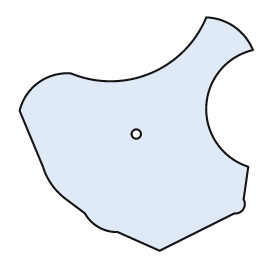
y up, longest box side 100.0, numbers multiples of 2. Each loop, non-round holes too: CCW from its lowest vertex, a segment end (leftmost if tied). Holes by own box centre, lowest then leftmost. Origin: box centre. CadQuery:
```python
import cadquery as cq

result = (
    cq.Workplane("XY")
    .moveTo(10.0, -50.0)
    .lineTo(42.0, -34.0)
    .threePointArc((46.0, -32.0), (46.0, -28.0))
    .lineTo(48.0, -14.0)
    .threePointArc((30.0, 12.0), (50.0, 36.0))
    .threePointArc((42.0, 46.0), (30.0, 50.0))
    .threePointArc((6.0, 26.0), (-28.0, 26.0))
    .threePointArc((-42.0, 22.0), (-50.0, 10.0))
    .lineTo(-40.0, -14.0)
    .threePointArc((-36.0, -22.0), (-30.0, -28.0))
    .lineTo(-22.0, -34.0)
    .threePointArc((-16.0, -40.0), (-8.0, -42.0))
    .close()
    .moveTo(0.0, 0.0)
    .circle(2.0)
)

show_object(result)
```